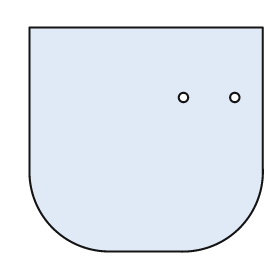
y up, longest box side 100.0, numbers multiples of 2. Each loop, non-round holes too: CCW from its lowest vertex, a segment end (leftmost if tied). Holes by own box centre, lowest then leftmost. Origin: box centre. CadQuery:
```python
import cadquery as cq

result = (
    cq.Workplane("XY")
    .moveTo(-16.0, -48.0)
    .lineTo(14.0, -48.0)
    .threePointArc((40.0, -38.0), (50.0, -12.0))
    .lineTo(50.0, 48.0)
    .lineTo(-50.0, 48.0)
    .lineTo(-50.0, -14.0)
    .threePointArc((-40.0, -38.0), (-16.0, -48.0))
    .close()
    .moveTo(16.0, 18.0)
    .circle(2.0)
    .moveTo(38.0, 18.0)
    .circle(2.0)
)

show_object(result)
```